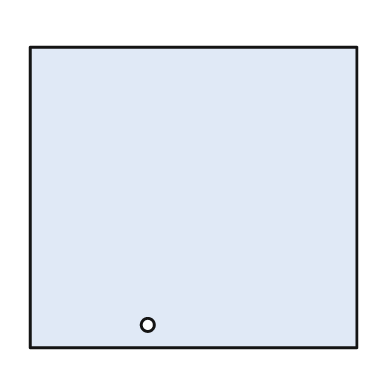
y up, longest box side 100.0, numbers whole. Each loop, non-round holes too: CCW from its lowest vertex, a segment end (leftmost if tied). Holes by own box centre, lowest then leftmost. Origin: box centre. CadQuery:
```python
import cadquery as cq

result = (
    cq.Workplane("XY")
    .moveTo(-50.0, -46.0)
    .lineTo(50.0, -46.0)
    .lineTo(50.0, 46.0)
    .lineTo(-50.0, 46.0)
    .close()
    .moveTo(-14.0, -39.0)
    .circle(2.0)
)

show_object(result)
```